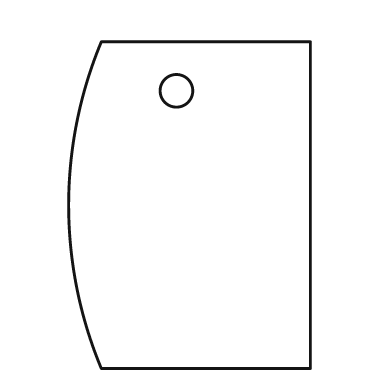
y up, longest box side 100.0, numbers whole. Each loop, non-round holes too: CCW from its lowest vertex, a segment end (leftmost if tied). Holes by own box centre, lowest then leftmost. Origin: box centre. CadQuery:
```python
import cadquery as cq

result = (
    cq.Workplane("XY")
    .moveTo(-27.0, -50.0)
    .lineTo(37.0, -50.0)
    .lineTo(37.0, 50.0)
    .lineTo(-27.0, 50.0)
    .threePointArc((-37.0, 0.0), (-27.0, -50.0))
    .close()
    .moveTo(-4.0, 35.0)
    .circle(5.0)
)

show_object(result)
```